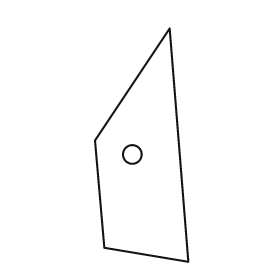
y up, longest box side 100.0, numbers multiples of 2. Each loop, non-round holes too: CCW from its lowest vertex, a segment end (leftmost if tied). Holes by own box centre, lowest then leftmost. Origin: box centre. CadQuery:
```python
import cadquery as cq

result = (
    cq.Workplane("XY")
    .moveTo(20.0, -50.0)
    .lineTo(12.0, 50.0)
    .lineTo(-20.0, 2.0)
    .lineTo(-16.0, -44.0)
    .close()
    .moveTo(-4.0, -4.0)
    .circle(4.0)
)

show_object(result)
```